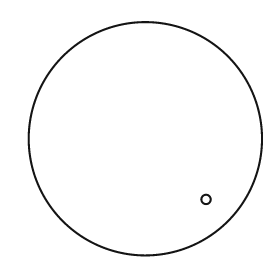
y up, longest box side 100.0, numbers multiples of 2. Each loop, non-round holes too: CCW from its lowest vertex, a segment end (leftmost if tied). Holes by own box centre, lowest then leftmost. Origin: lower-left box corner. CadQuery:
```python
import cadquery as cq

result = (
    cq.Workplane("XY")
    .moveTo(50.0, 50.0)
    .circle(50.0)
    .moveTo(76.0, 24.0)
    .circle(2.0)
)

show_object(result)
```